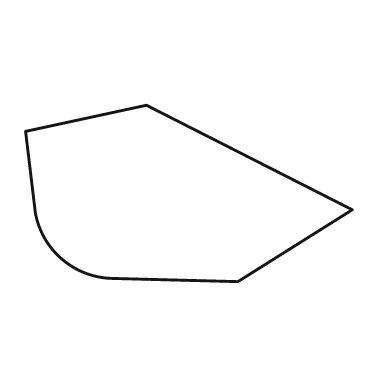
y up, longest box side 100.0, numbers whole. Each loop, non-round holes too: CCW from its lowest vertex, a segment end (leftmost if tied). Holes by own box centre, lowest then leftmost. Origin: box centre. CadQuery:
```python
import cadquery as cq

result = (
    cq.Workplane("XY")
    .moveTo(15.0, -27.0)
    .lineTo(50.0, -5.0)
    .lineTo(-13.0, 27.0)
    .lineTo(-50.0, 19.0)
    .lineTo(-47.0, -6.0)
    .threePointArc((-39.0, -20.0), (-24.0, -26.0))
    .close()
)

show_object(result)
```